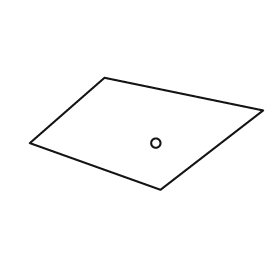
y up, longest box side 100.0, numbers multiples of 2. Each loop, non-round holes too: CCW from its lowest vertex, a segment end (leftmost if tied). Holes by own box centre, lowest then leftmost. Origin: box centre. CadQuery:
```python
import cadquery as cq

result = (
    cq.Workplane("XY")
    .moveTo(6.0, -24.0)
    .lineTo(50.0, 10.0)
    .lineTo(-18.0, 24.0)
    .lineTo(-50.0, -4.0)
    .close()
    .moveTo(4.0, -4.0)
    .circle(2.0)
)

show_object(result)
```